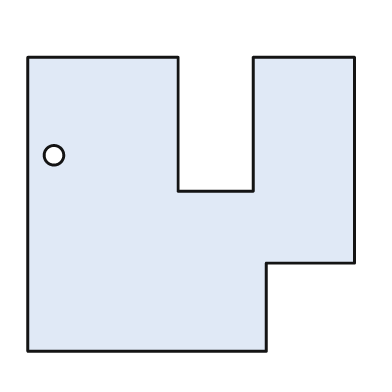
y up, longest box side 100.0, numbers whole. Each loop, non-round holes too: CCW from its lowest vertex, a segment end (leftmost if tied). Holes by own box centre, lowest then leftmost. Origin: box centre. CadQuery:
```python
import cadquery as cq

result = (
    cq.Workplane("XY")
    .moveTo(-50.0, -45.0)
    .lineTo(23.0, -45.0)
    .lineTo(23.0, -18.0)
    .lineTo(50.0, -18.0)
    .lineTo(50.0, 45.0)
    .lineTo(19.0, 45.0)
    .lineTo(19.0, 4.0)
    .lineTo(-4.0, 4.0)
    .lineTo(-4.0, 45.0)
    .lineTo(-50.0, 45.0)
    .close()
    .moveTo(-42.0, 15.0)
    .circle(3.0)
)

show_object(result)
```